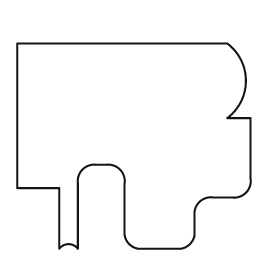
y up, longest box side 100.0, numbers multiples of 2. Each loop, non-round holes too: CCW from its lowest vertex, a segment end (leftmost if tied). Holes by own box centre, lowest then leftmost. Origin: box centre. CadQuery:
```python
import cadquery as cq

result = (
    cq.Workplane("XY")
    .moveTo(-32.0, -44.0)
    .threePointArc((-28.0, -42.0), (-24.0, -44.0))
    .lineTo(-24.0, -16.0)
    .threePointArc((-22.0, -10.0), (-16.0, -8.0))
    .lineTo(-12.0, -8.0)
    .threePointArc((-6.0, -10.0), (-4.0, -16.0))
    .lineTo(-4.0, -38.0)
    .threePointArc((-2.0, -42.0), (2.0, -44.0))
    .lineTo(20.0, -44.0)
    .threePointArc((24.0, -42.0), (26.0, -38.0))
    .lineTo(26.0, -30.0)
    .threePointArc((28.0, -24.0), (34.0, -22.0))
    .lineTo(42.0, -22.0)
    .threePointArc((48.0, -20.0), (50.0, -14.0))
    .lineTo(50.0, 12.0)
    .lineTo(40.0, 12.0)
    .threePointArc((48.0, 28.0), (40.0, 44.0))
    .lineTo(-50.0, 44.0)
    .lineTo(-50.0, -18.0)
    .lineTo(-32.0, -18.0)
    .close()
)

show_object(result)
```